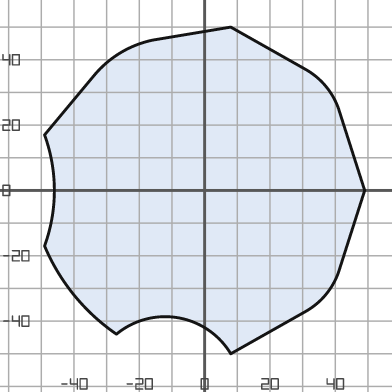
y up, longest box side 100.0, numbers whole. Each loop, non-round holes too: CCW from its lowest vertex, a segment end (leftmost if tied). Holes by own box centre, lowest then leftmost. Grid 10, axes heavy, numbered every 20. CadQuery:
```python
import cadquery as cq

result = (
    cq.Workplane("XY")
    .moveTo(8.0, -50.0)
    .lineTo(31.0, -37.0)
    .threePointArc((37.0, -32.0), (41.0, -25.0))
    .lineTo(49.0, 0.0)
    .lineTo(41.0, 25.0)
    .threePointArc((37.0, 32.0), (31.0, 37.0))
    .lineTo(8.0, 50.0)
    .lineTo(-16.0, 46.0)
    .threePointArc((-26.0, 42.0), (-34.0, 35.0))
    .lineTo(-49.0, 17.0)
    .threePointArc((-46.0, 0.0), (-49.0, -17.0))
    .threePointArc((-40.0, -32.0), (-27.0, -44.0))
    .threePointArc((-8.0, -39.0), (8.0, -50.0))
    .close()
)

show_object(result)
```